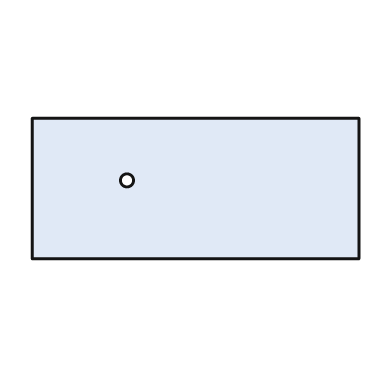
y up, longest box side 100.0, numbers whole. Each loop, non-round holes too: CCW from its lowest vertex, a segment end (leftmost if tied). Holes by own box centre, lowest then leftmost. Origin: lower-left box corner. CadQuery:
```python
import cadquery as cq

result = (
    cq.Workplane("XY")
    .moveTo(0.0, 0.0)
    .lineTo(100.0, 0.0)
    .lineTo(100.0, 43.0)
    .lineTo(0.0, 43.0)
    .close()
    .moveTo(29.0, 24.0)
    .circle(2.0)
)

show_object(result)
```